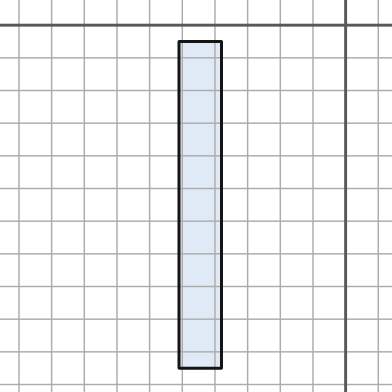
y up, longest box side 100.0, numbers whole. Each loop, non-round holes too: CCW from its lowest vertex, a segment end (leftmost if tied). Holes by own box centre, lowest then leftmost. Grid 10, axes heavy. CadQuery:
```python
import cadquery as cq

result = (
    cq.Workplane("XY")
    .moveTo(-51.0, -105.0)
    .lineTo(-38.0, -105.0)
    .lineTo(-38.0, -5.0)
    .lineTo(-51.0, -5.0)
    .close()
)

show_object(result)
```